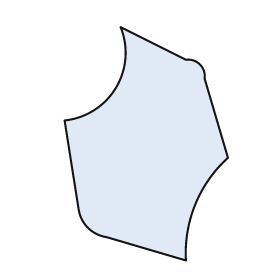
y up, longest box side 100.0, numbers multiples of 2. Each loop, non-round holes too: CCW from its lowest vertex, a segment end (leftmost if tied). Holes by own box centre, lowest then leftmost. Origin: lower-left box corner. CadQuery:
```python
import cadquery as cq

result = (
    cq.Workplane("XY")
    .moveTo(52.0, 0.0)
    .threePointArc((56.0, 24.0), (70.0, 44.0))
    .lineTo(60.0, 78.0)
    .threePointArc((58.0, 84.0), (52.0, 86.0))
    .lineTo(24.0, 100.0)
    .threePointArc((22.0, 74.0), (0.0, 60.0))
    .lineTo(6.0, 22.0)
    .threePointArc((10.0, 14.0), (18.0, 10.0))
    .close()
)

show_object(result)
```